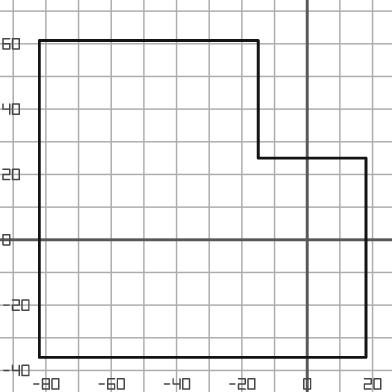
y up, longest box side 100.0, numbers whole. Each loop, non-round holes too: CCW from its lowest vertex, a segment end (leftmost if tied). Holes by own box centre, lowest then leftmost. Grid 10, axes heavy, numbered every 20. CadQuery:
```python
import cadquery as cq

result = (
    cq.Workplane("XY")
    .moveTo(-82.0, -36.0)
    .lineTo(18.0, -36.0)
    .lineTo(18.0, 25.0)
    .lineTo(-15.0, 25.0)
    .lineTo(-15.0, 61.0)
    .lineTo(-82.0, 61.0)
    .close()
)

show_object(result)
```